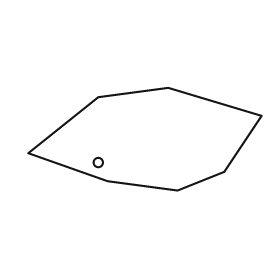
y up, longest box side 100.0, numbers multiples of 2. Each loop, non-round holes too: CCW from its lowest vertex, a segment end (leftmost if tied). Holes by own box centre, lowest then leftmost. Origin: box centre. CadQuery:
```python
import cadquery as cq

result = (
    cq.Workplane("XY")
    .moveTo(14.0, -22.0)
    .lineTo(34.0, -14.0)
    .lineTo(50.0, 10.0)
    .lineTo(10.0, 22.0)
    .lineTo(-20.0, 18.0)
    .lineTo(-50.0, -6.0)
    .lineTo(-16.0, -18.0)
    .close()
    .moveTo(-20.0, -10.0)
    .circle(2.0)
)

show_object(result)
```